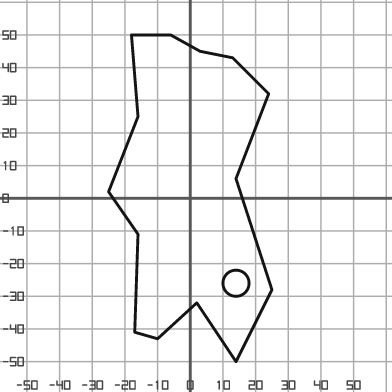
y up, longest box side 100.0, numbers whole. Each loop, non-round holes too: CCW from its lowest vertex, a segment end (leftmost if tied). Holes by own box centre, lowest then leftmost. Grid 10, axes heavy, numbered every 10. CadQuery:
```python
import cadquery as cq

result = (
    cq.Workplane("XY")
    .moveTo(14.0, -50.0)
    .lineTo(25.0, -28.0)
    .lineTo(14.0, 6.0)
    .lineTo(24.0, 32.0)
    .lineTo(13.0, 43.0)
    .lineTo(3.0, 45.0)
    .lineTo(-6.0, 50.0)
    .lineTo(-18.0, 50.0)
    .lineTo(-16.0, 25.0)
    .lineTo(-25.0, 2.0)
    .lineTo(-16.0, -11.0)
    .lineTo(-17.0, -41.0)
    .lineTo(-10.0, -43.0)
    .lineTo(2.0, -32.0)
    .close()
    .moveTo(14.0, -26.0)
    .circle(4.0)
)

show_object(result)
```